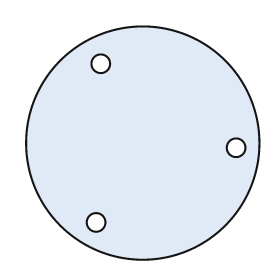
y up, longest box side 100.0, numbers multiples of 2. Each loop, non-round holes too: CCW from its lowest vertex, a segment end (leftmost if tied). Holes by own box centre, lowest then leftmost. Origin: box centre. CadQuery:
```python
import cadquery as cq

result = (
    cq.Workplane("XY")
    .moveTo(0.0, 0.0)
    .circle(50.0)
    .moveTo(-20.0, -34.0)
    .circle(4.0)
    .moveTo(40.0, -2.0)
    .circle(4.0)
    .moveTo(-18.0, 34.0)
    .circle(4.0)
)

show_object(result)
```